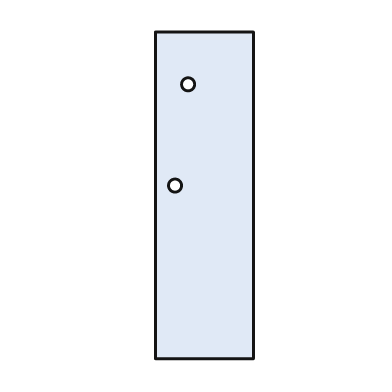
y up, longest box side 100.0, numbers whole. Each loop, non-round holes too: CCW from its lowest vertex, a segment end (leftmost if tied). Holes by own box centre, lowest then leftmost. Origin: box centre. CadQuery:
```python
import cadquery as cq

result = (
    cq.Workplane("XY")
    .moveTo(-15.0, -50.0)
    .lineTo(15.0, -50.0)
    .lineTo(15.0, 50.0)
    .lineTo(-15.0, 50.0)
    .close()
    .moveTo(-9.0, 3.0)
    .circle(2.0)
    .moveTo(-5.0, 34.0)
    .circle(2.0)
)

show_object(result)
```